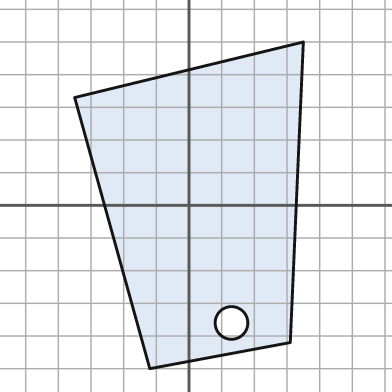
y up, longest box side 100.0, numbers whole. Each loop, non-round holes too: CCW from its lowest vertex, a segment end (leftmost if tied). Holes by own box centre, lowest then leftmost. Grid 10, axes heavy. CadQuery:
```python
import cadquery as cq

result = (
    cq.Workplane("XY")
    .moveTo(-12.0, -50.0)
    .lineTo(31.0, -42.0)
    .lineTo(35.0, 50.0)
    .lineTo(-35.0, 33.0)
    .close()
    .moveTo(13.0, -36.0)
    .circle(5.0)
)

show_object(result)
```